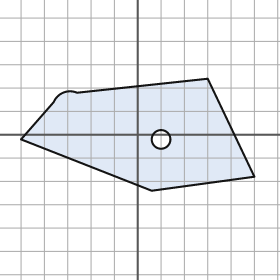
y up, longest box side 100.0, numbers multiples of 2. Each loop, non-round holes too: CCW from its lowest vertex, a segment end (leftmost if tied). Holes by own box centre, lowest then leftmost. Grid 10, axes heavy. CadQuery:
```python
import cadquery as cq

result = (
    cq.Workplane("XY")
    .moveTo(6.0, -24.0)
    .lineTo(50.0, -18.0)
    .lineTo(30.0, 24.0)
    .lineTo(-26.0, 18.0)
    .threePointArc((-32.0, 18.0), (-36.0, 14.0))
    .lineTo(-50.0, -2.0)
    .close()
    .moveTo(10.0, -2.0)
    .circle(4.0)
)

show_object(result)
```